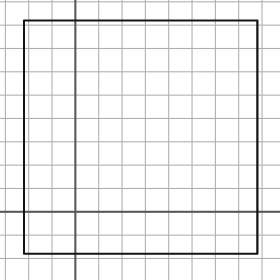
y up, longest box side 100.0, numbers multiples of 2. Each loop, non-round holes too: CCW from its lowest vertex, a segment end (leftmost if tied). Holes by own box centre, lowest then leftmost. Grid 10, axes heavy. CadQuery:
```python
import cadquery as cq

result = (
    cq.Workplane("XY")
    .moveTo(-22.0, -18.0)
    .lineTo(78.0, -18.0)
    .lineTo(78.0, 82.0)
    .lineTo(-22.0, 82.0)
    .close()
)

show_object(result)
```